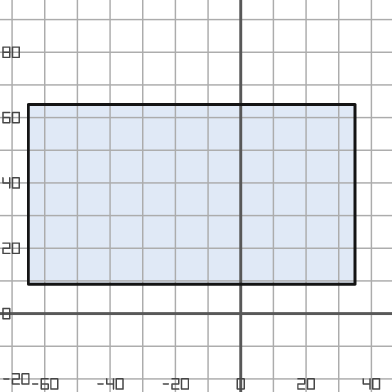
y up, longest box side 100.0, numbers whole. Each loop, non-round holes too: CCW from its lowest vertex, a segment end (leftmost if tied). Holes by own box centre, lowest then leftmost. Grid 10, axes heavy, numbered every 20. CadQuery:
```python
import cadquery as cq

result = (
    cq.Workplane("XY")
    .moveTo(-65.0, 9.0)
    .lineTo(35.0, 9.0)
    .lineTo(35.0, 64.0)
    .lineTo(-65.0, 64.0)
    .close()
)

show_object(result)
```